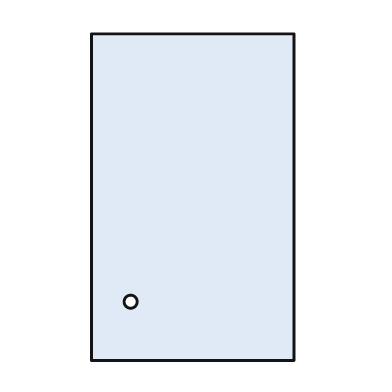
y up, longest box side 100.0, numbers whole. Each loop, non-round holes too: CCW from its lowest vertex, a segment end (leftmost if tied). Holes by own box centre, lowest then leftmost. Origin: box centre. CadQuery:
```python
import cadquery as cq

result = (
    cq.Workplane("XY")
    .moveTo(-31.0, -50.0)
    .lineTo(31.0, -50.0)
    .lineTo(31.0, 50.0)
    .lineTo(-31.0, 50.0)
    .close()
    .moveTo(-19.0, -32.0)
    .circle(2.0)
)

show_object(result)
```